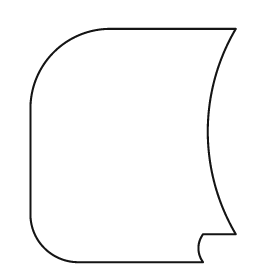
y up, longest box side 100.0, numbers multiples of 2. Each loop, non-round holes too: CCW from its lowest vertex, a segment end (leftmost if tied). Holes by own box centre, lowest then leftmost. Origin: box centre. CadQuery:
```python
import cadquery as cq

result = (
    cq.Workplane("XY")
    .moveTo(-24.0, -50.0)
    .lineTo(30.0, -50.0)
    .threePointArc((28.0, -44.0), (30.0, -38.0))
    .lineTo(44.0, -38.0)
    .threePointArc((32.0, 6.0), (44.0, 50.0))
    .lineTo(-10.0, 50.0)
    .threePointArc((-34.0, 40.0), (-44.0, 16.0))
    .lineTo(-44.0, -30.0)
    .threePointArc((-38.0, -44.0), (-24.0, -50.0))
    .close()
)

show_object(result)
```